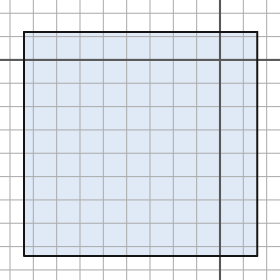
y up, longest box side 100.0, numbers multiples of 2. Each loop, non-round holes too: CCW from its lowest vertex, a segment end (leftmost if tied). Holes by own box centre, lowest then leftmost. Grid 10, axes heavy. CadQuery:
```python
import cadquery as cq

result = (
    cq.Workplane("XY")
    .moveTo(-84.0, -84.0)
    .lineTo(16.0, -84.0)
    .lineTo(16.0, 12.0)
    .lineTo(-84.0, 12.0)
    .close()
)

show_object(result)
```